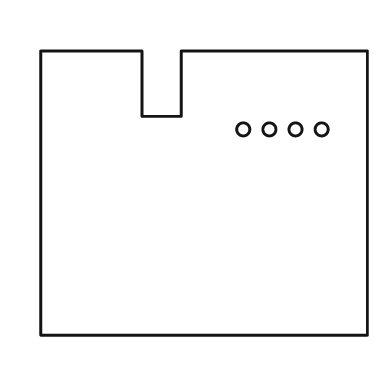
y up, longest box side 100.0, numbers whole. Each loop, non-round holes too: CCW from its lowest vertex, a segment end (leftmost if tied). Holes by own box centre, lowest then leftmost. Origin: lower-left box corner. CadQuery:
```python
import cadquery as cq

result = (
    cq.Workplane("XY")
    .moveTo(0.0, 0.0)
    .lineTo(100.0, 0.0)
    .lineTo(100.0, 87.0)
    .lineTo(43.0, 87.0)
    .lineTo(43.0, 67.0)
    .lineTo(31.0, 67.0)
    .lineTo(31.0, 87.0)
    .lineTo(0.0, 87.0)
    .close()
    .moveTo(62.0, 63.0)
    .circle(2.0)
    .moveTo(70.0, 63.0)
    .circle(2.0)
    .moveTo(78.0, 63.0)
    .circle(2.0)
    .moveTo(86.0, 63.0)
    .circle(2.0)
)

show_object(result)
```